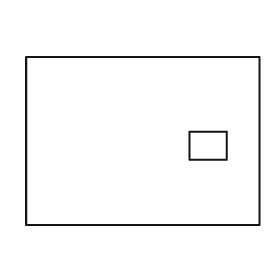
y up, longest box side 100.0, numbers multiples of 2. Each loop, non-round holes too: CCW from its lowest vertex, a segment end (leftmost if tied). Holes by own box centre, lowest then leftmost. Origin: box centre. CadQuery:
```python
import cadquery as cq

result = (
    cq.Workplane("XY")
    .moveTo(-50.0, -36.0)
    .lineTo(50.0, -36.0)
    .lineTo(50.0, 36.0)
    .lineTo(-50.0, 36.0)
    .close()
    .moveTo(20.0, -8.0)
    .lineTo(36.0, -8.0)
    .lineTo(36.0, 4.0)
    .lineTo(20.0, 4.0)
    .close()
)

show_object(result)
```